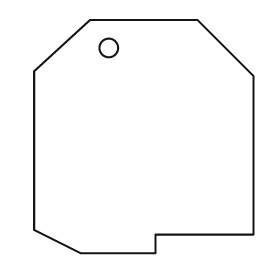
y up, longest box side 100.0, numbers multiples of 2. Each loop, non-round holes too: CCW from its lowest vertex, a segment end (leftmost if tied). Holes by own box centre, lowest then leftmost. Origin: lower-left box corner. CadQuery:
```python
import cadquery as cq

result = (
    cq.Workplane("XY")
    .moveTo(20.0, 0.0)
    .lineTo(52.0, 0.0)
    .lineTo(52.0, 8.0)
    .lineTo(94.0, 8.0)
    .lineTo(94.0, 76.0)
    .lineTo(70.0, 100.0)
    .lineTo(24.0, 100.0)
    .lineTo(0.0, 78.0)
    .lineTo(0.0, 10.0)
    .close()
    .moveTo(32.0, 88.0)
    .circle(4.0)
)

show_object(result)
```